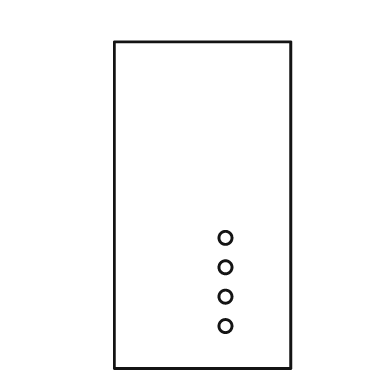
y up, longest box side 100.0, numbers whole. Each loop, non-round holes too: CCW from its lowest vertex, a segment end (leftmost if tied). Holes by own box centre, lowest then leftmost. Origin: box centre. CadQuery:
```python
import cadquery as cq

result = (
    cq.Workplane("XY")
    .moveTo(-27.0, -50.0)
    .lineTo(27.0, -50.0)
    .lineTo(27.0, 50.0)
    .lineTo(-27.0, 50.0)
    .close()
    .moveTo(7.0, -37.0)
    .circle(2.0)
    .moveTo(7.0, -28.0)
    .circle(2.0)
    .moveTo(7.0, -19.0)
    .circle(2.0)
    .moveTo(7.0, -10.0)
    .circle(2.0)
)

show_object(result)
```